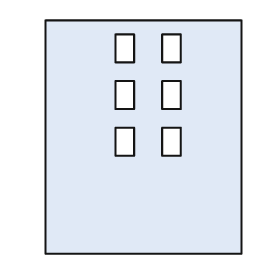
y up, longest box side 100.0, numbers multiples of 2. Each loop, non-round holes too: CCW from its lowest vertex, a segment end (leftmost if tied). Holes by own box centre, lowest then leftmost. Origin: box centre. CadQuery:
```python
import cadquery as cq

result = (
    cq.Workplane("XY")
    .moveTo(-42.0, -50.0)
    .lineTo(42.0, -50.0)
    .lineTo(42.0, 50.0)
    .lineTo(-42.0, 50.0)
    .close()
    .moveTo(-12.0, -8.0)
    .lineTo(-4.0, -8.0)
    .lineTo(-4.0, 4.0)
    .lineTo(-12.0, 4.0)
    .close()
    .moveTo(8.0, -8.0)
    .lineTo(16.0, -8.0)
    .lineTo(16.0, 4.0)
    .lineTo(8.0, 4.0)
    .close()
    .moveTo(-12.0, 12.0)
    .lineTo(-4.0, 12.0)
    .lineTo(-4.0, 24.0)
    .lineTo(-12.0, 24.0)
    .close()
    .moveTo(8.0, 12.0)
    .lineTo(16.0, 12.0)
    .lineTo(16.0, 24.0)
    .lineTo(8.0, 24.0)
    .close()
    .moveTo(-12.0, 32.0)
    .lineTo(-4.0, 32.0)
    .lineTo(-4.0, 44.0)
    .lineTo(-12.0, 44.0)
    .close()
    .moveTo(8.0, 32.0)
    .lineTo(16.0, 32.0)
    .lineTo(16.0, 44.0)
    .lineTo(8.0, 44.0)
    .close()
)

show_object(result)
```